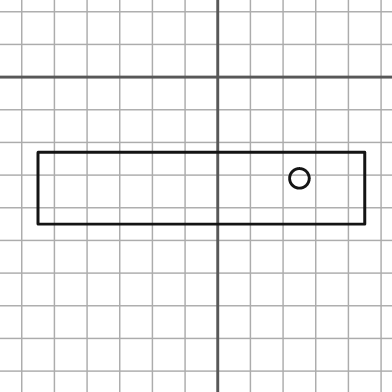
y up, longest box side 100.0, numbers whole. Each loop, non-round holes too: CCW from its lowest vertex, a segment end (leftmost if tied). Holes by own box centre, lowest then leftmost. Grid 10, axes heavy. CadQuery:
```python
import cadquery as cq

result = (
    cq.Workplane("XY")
    .moveTo(-55.0, -45.0)
    .lineTo(45.0, -45.0)
    .lineTo(45.0, -23.0)
    .lineTo(-55.0, -23.0)
    .close()
    .moveTo(25.0, -31.0)
    .circle(3.0)
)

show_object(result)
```